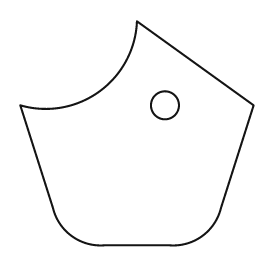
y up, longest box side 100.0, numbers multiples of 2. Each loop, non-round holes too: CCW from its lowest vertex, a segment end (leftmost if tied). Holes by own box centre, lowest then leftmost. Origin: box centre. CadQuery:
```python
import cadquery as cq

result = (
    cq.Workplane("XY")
    .moveTo(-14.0, -48.0)
    .lineTo(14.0, -48.0)
    .threePointArc((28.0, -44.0), (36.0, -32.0))
    .lineTo(50.0, 12.0)
    .lineTo(0.0, 48.0)
    .threePointArc((-16.0, 18.0), (-50.0, 12.0))
    .lineTo(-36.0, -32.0)
    .threePointArc((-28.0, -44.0), (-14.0, -48.0))
    .close()
    .moveTo(12.0, 12.0)
    .circle(6.0)
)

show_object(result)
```